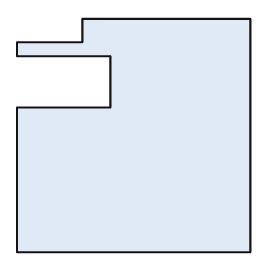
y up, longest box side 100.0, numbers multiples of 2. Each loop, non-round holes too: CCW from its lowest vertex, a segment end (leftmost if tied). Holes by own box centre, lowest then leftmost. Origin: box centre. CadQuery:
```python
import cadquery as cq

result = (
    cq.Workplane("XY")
    .moveTo(-50.0, -50.0)
    .lineTo(50.0, -50.0)
    .lineTo(50.0, 50.0)
    .lineTo(-22.0, 50.0)
    .lineTo(-22.0, 40.0)
    .lineTo(-50.0, 40.0)
    .lineTo(-50.0, 34.0)
    .lineTo(-10.0, 34.0)
    .lineTo(-10.0, 12.0)
    .lineTo(-50.0, 12.0)
    .close()
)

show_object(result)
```